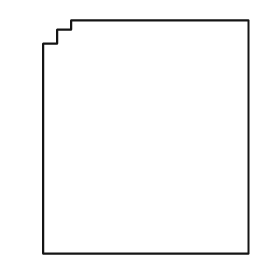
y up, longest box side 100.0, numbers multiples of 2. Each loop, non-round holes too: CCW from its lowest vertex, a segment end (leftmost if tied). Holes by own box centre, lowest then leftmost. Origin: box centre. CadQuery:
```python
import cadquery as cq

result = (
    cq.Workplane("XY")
    .moveTo(-44.0, -50.0)
    .lineTo(44.0, -50.0)
    .lineTo(44.0, 50.0)
    .lineTo(-32.0, 50.0)
    .lineTo(-32.0, 46.0)
    .lineTo(-38.0, 46.0)
    .lineTo(-38.0, 40.0)
    .lineTo(-44.0, 40.0)
    .close()
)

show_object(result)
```